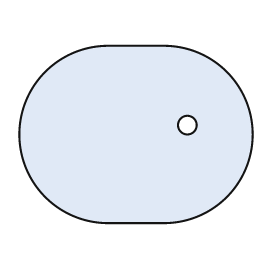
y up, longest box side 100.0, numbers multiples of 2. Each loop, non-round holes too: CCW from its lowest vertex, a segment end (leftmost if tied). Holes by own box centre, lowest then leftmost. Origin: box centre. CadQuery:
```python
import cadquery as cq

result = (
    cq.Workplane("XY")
    .moveTo(-12.0, -38.0)
    .lineTo(12.0, -38.0)
    .threePointArc((50.0, 0.0), (12.0, 38.0))
    .lineTo(-12.0, 38.0)
    .threePointArc((-50.0, 0.0), (-12.0, -38.0))
    .close()
    .moveTo(22.0, 4.0)
    .circle(4.0)
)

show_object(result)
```